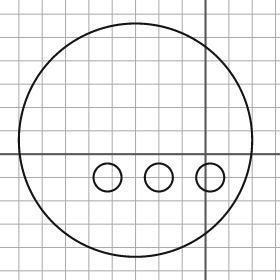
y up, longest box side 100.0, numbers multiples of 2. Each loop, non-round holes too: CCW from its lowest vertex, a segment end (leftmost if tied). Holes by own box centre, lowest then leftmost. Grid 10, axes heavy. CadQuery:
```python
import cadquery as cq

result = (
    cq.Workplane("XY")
    .moveTo(-30.0, 6.0)
    .circle(50.0)
    .moveTo(-42.0, -10.0)
    .circle(6.0)
    .moveTo(-20.0, -10.0)
    .circle(6.0)
    .moveTo(2.0, -10.0)
    .circle(6.0)
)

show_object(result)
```